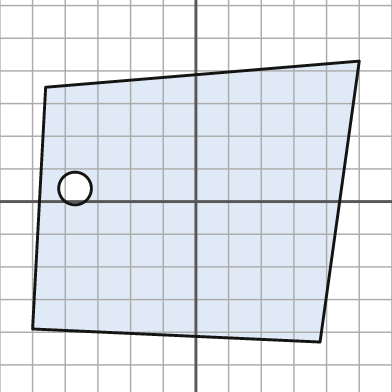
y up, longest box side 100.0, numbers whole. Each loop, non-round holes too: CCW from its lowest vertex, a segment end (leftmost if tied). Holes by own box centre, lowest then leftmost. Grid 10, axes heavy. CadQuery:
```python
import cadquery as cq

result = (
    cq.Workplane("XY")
    .moveTo(38.0, -43.0)
    .lineTo(50.0, 43.0)
    .lineTo(-46.0, 35.0)
    .lineTo(-50.0, -39.0)
    .close()
    .moveTo(-37.0, 4.0)
    .circle(5.0)
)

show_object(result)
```